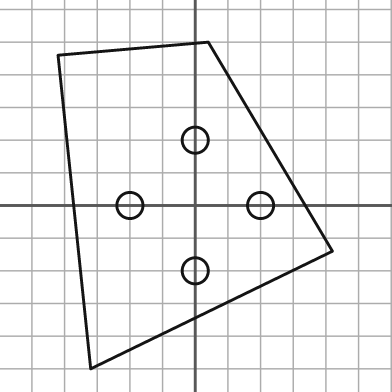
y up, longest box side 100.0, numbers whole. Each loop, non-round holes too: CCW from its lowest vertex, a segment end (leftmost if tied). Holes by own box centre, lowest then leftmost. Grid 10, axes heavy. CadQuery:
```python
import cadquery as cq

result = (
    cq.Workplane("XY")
    .moveTo(-32.0, -50.0)
    .lineTo(42.0, -14.0)
    .lineTo(4.0, 50.0)
    .lineTo(-42.0, 46.0)
    .close()
    .moveTo(0.0, -20.0)
    .circle(4.0)
    .moveTo(-20.0, 0.0)
    .circle(4.0)
    .moveTo(20.0, 0.0)
    .circle(4.0)
    .moveTo(0.0, 20.0)
    .circle(4.0)
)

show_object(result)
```